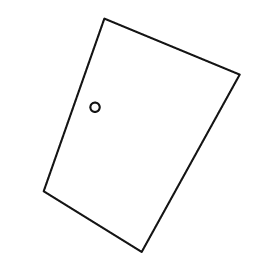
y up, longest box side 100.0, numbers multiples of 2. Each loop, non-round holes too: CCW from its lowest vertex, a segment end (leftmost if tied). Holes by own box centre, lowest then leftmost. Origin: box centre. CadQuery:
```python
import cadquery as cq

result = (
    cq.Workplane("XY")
    .moveTo(0.0, -50.0)
    .lineTo(42.0, 26.0)
    .lineTo(-16.0, 50.0)
    .lineTo(-42.0, -24.0)
    .close()
    .moveTo(-20.0, 12.0)
    .circle(2.0)
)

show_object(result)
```